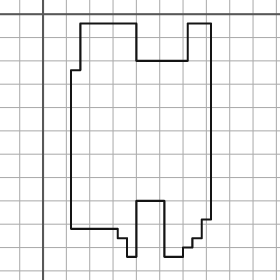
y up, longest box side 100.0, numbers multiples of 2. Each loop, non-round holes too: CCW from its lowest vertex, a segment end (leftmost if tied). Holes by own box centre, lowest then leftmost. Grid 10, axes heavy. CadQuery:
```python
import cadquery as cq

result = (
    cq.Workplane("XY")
    .moveTo(36.0, -104.0)
    .lineTo(40.0, -104.0)
    .lineTo(40.0, -80.0)
    .lineTo(52.0, -80.0)
    .lineTo(52.0, -104.0)
    .lineTo(60.0, -104.0)
    .lineTo(60.0, -100.0)
    .lineTo(64.0, -100.0)
    .lineTo(64.0, -96.0)
    .lineTo(68.0, -96.0)
    .lineTo(68.0, -88.0)
    .lineTo(72.0, -88.0)
    .lineTo(72.0, -4.0)
    .lineTo(62.0, -4.0)
    .lineTo(62.0, -20.0)
    .lineTo(40.0, -20.0)
    .lineTo(40.0, -4.0)
    .lineTo(16.0, -4.0)
    .lineTo(16.0, -24.0)
    .lineTo(12.0, -24.0)
    .lineTo(12.0, -92.0)
    .lineTo(32.0, -92.0)
    .lineTo(32.0, -96.0)
    .lineTo(36.0, -96.0)
    .close()
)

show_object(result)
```